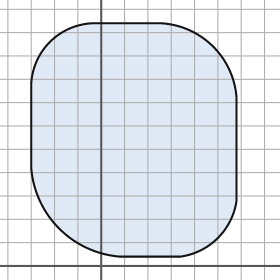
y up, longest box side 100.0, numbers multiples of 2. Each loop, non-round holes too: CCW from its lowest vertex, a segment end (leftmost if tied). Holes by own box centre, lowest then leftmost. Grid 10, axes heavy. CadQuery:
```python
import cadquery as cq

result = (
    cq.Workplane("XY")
    .moveTo(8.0, 4.0)
    .lineTo(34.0, 4.0)
    .threePointArc((50.0, 12.0), (58.0, 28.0))
    .lineTo(58.0, 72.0)
    .threePointArc((48.0, 94.0), (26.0, 104.0))
    .lineTo(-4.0, 104.0)
    .threePointArc((-22.0, 96.0), (-30.0, 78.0))
    .lineTo(-30.0, 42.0)
    .threePointArc((-18.0, 16.0), (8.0, 4.0))
    .close()
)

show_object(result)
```